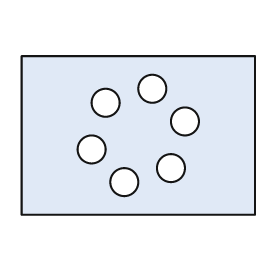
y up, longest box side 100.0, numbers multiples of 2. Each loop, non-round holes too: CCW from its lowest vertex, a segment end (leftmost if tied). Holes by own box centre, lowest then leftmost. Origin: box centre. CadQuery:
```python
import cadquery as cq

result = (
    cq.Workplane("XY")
    .moveTo(-50.0, -34.0)
    .lineTo(50.0, -34.0)
    .lineTo(50.0, 34.0)
    .lineTo(-50.0, 34.0)
    .close()
    .moveTo(-6.0, -20.0)
    .circle(6.0)
    .moveTo(14.0, -14.0)
    .circle(6.0)
    .moveTo(-20.0, -6.0)
    .circle(6.0)
    .moveTo(20.0, 6.0)
    .circle(6.0)
    .moveTo(-14.0, 14.0)
    .circle(6.0)
    .moveTo(6.0, 20.0)
    .circle(6.0)
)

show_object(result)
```